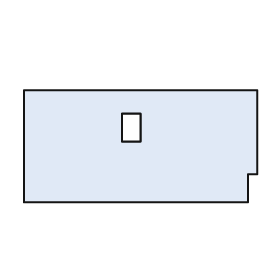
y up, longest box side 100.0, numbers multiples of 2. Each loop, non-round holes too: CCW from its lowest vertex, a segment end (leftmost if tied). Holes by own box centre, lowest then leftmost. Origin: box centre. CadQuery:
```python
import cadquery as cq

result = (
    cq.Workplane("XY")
    .moveTo(-50.0, -24.0)
    .lineTo(46.0, -24.0)
    .lineTo(46.0, -12.0)
    .lineTo(50.0, -12.0)
    .lineTo(50.0, 24.0)
    .lineTo(-50.0, 24.0)
    .close()
    .moveTo(-8.0, 2.0)
    .lineTo(0.0, 2.0)
    .lineTo(0.0, 14.0)
    .lineTo(-8.0, 14.0)
    .close()
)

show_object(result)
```